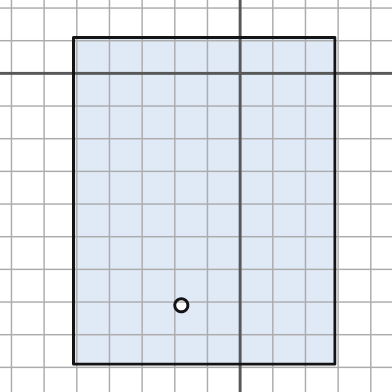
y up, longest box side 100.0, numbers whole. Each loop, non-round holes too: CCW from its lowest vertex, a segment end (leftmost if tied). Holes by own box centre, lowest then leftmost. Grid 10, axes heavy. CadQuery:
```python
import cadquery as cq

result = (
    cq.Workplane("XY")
    .moveTo(-51.0, -89.0)
    .lineTo(29.0, -89.0)
    .lineTo(29.0, 11.0)
    .lineTo(-51.0, 11.0)
    .close()
    .moveTo(-18.0, -71.0)
    .circle(2.0)
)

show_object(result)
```